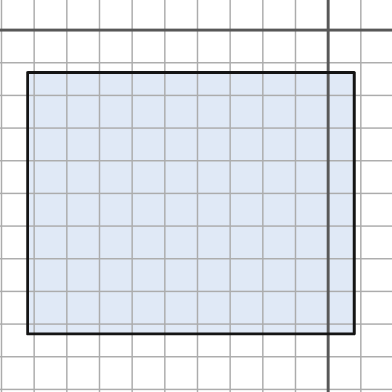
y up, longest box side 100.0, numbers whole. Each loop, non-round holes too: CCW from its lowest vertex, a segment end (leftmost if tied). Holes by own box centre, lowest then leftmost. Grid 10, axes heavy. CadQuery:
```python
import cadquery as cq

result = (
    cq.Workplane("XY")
    .moveTo(-92.0, -93.0)
    .lineTo(8.0, -93.0)
    .lineTo(8.0, -13.0)
    .lineTo(-92.0, -13.0)
    .close()
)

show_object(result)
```